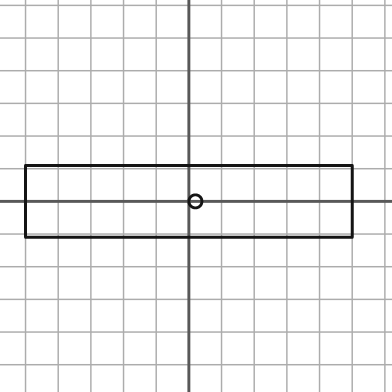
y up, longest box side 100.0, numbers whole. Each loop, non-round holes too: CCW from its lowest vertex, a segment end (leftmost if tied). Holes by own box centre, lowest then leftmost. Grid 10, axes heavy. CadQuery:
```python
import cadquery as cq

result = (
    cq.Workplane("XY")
    .moveTo(-50.0, -11.0)
    .lineTo(50.0, -11.0)
    .lineTo(50.0, 11.0)
    .lineTo(-50.0, 11.0)
    .close()
    .moveTo(2.0, 0.0)
    .circle(2.0)
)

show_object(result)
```